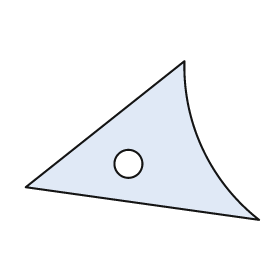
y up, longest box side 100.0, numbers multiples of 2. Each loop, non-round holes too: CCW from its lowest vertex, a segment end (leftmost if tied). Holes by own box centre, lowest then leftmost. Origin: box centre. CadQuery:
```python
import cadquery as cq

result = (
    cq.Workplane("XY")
    .moveTo(50.0, -34.0)
    .threePointArc((26.0, -4.0), (18.0, 34.0))
    .lineTo(-50.0, -20.0)
    .close()
    .moveTo(-6.0, -10.0)
    .circle(6.0)
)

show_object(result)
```